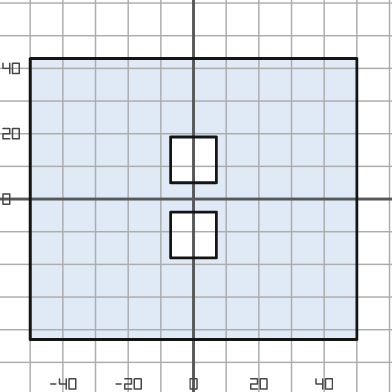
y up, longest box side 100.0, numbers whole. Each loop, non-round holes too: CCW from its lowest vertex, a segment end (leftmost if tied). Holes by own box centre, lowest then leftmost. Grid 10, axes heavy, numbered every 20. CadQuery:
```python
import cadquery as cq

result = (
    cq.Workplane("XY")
    .moveTo(-50.0, -43.0)
    .lineTo(50.0, -43.0)
    .lineTo(50.0, 43.0)
    .lineTo(-50.0, 43.0)
    .close()
    .moveTo(-7.0, -18.0)
    .lineTo(7.0, -18.0)
    .lineTo(7.0, -4.0)
    .lineTo(-7.0, -4.0)
    .close()
    .moveTo(-7.0, 5.0)
    .lineTo(7.0, 5.0)
    .lineTo(7.0, 19.0)
    .lineTo(-7.0, 19.0)
    .close()
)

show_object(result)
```